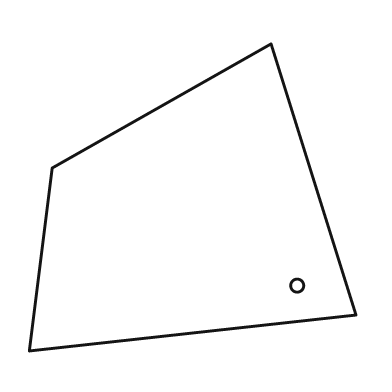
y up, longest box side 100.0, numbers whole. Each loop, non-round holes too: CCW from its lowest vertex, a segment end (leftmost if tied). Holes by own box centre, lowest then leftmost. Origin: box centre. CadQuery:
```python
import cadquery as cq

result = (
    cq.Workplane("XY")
    .moveTo(-50.0, -47.0)
    .lineTo(50.0, -36.0)
    .lineTo(24.0, 47.0)
    .lineTo(-43.0, 9.0)
    .close()
    .moveTo(32.0, -27.0)
    .circle(2.0)
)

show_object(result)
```